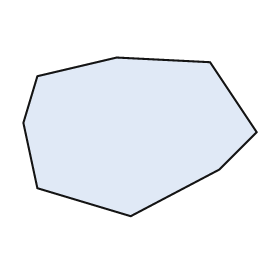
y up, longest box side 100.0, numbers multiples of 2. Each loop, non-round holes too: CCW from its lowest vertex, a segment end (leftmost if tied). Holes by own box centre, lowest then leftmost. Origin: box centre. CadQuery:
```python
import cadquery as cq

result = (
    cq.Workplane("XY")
    .moveTo(-4.0, -34.0)
    .lineTo(34.0, -14.0)
    .lineTo(50.0, 2.0)
    .lineTo(30.0, 32.0)
    .lineTo(-10.0, 34.0)
    .lineTo(-44.0, 26.0)
    .lineTo(-50.0, 6.0)
    .lineTo(-44.0, -22.0)
    .close()
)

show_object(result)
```